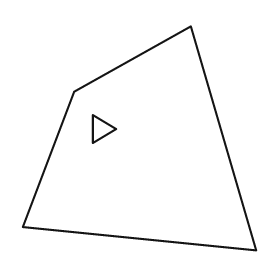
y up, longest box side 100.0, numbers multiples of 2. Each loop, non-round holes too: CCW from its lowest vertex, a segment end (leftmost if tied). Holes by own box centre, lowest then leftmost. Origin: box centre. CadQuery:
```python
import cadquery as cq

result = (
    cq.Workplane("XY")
    .moveTo(50.0, -48.0)
    .lineTo(22.0, 48.0)
    .lineTo(-28.0, 20.0)
    .lineTo(-50.0, -38.0)
    .close()
    .moveTo(-20.0, -2.0)
    .lineTo(-10.0, 4.0)
    .lineTo(-20.0, 10.0)
    .close()
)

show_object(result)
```